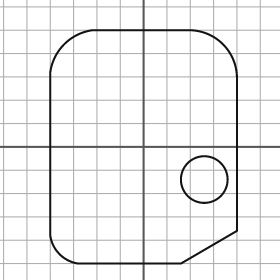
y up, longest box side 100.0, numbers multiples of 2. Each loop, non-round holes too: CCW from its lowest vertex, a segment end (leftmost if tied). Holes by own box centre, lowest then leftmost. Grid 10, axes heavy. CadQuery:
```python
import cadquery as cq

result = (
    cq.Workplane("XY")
    .moveTo(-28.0, -50.0)
    .lineTo(16.0, -50.0)
    .lineTo(40.0, -36.0)
    .lineTo(40.0, 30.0)
    .threePointArc((34.0, 44.0), (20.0, 50.0))
    .lineTo(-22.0, 50.0)
    .threePointArc((-34.0, 44.0), (-40.0, 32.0))
    .lineTo(-40.0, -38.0)
    .threePointArc((-36.0, -46.0), (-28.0, -50.0))
    .close()
    .moveTo(26.0, -14.0)
    .circle(10.0)
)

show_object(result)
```